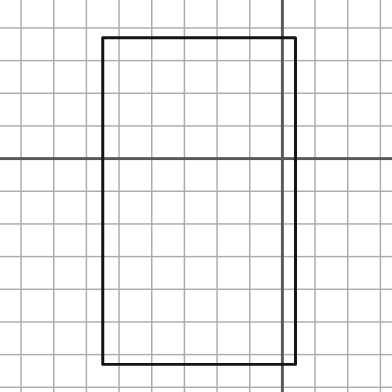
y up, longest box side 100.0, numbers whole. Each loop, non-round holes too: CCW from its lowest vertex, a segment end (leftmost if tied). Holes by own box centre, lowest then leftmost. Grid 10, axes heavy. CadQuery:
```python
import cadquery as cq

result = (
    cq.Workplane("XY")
    .moveTo(-55.0, -63.0)
    .lineTo(4.0, -63.0)
    .lineTo(4.0, 37.0)
    .lineTo(-55.0, 37.0)
    .close()
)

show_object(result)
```